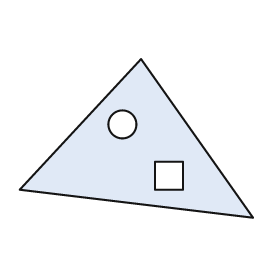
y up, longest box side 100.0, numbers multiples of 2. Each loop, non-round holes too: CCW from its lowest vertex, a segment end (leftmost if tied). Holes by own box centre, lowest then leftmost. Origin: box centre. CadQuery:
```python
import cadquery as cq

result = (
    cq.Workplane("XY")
    .moveTo(50.0, -34.0)
    .lineTo(2.0, 34.0)
    .lineTo(-50.0, -22.0)
    .close()
    .moveTo(8.0, -22.0)
    .lineTo(20.0, -22.0)
    .lineTo(20.0, -10.0)
    .lineTo(8.0, -10.0)
    .close()
    .moveTo(-6.0, 6.0)
    .circle(6.0)
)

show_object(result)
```